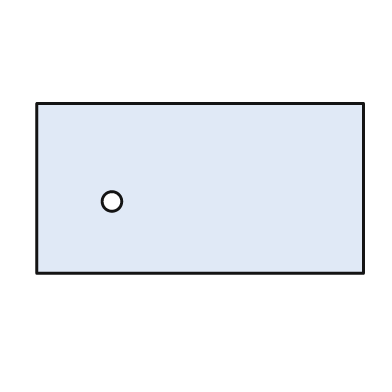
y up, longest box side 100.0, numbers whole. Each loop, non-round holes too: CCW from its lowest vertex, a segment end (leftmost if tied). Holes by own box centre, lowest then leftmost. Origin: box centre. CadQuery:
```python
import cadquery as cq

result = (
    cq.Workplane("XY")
    .moveTo(-50.0, -26.0)
    .lineTo(50.0, -26.0)
    .lineTo(50.0, 26.0)
    .lineTo(-50.0, 26.0)
    .close()
    .moveTo(-27.0, -4.0)
    .circle(3.0)
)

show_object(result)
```